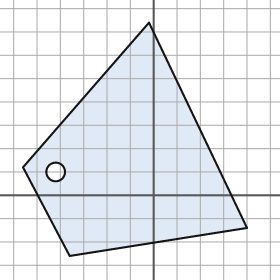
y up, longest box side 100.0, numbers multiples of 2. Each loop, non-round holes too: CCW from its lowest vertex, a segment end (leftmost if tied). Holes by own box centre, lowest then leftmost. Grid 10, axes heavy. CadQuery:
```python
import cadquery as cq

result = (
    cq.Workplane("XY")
    .moveTo(-36.0, -26.0)
    .lineTo(40.0, -14.0)
    .lineTo(-2.0, 74.0)
    .lineTo(-56.0, 12.0)
    .close()
    .moveTo(-42.0, 10.0)
    .circle(4.0)
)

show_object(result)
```